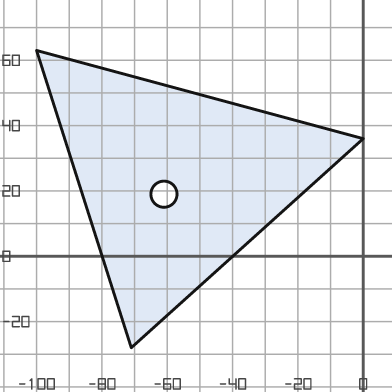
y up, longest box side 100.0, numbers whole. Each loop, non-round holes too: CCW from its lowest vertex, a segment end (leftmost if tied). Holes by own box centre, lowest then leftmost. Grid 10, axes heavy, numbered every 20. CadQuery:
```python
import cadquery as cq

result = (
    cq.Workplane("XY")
    .moveTo(-71.0, -28.0)
    .lineTo(0.0, 36.0)
    .lineTo(-100.0, 63.0)
    .close()
    .moveTo(-61.0, 19.0)
    .circle(4.0)
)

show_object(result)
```